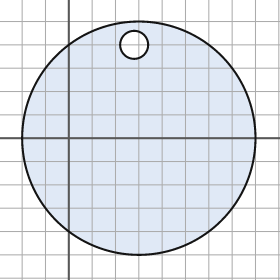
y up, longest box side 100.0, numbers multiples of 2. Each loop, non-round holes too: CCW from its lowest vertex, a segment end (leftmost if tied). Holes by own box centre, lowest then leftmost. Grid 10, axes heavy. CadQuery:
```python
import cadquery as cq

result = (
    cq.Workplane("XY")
    .moveTo(30.0, 0.0)
    .circle(50.0)
    .moveTo(28.0, 40.0)
    .circle(6.0)
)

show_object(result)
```